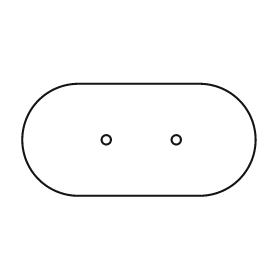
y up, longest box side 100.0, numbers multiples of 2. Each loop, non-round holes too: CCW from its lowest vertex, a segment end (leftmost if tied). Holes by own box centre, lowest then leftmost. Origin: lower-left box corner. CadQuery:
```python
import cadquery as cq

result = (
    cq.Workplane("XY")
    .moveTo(24.0, 0.0)
    .lineTo(76.0, 0.0)
    .threePointArc((100.0, 24.0), (76.0, 48.0))
    .lineTo(24.0, 48.0)
    .threePointArc((0.0, 24.0), (24.0, 0.0))
    .close()
    .moveTo(36.0, 24.0)
    .circle(2.0)
    .moveTo(66.0, 24.0)
    .circle(2.0)
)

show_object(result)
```